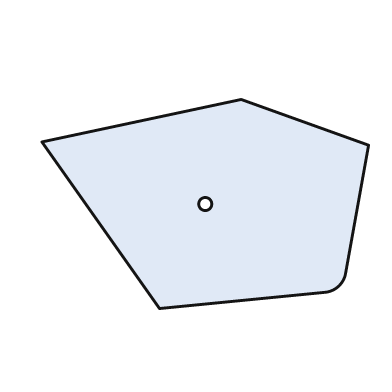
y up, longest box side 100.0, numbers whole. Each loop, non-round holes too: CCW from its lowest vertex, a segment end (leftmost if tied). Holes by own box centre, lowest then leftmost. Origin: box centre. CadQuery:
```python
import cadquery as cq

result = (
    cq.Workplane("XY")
    .moveTo(-14.0, -32.0)
    .lineTo(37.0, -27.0)
    .threePointArc((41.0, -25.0), (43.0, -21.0))
    .lineTo(50.0, 18.0)
    .lineTo(11.0, 32.0)
    .lineTo(-50.0, 19.0)
    .close()
    .moveTo(0.0, 0.0)
    .circle(2.0)
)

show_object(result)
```